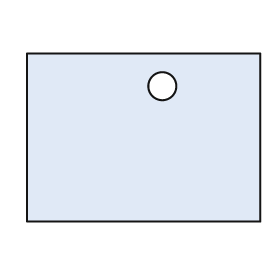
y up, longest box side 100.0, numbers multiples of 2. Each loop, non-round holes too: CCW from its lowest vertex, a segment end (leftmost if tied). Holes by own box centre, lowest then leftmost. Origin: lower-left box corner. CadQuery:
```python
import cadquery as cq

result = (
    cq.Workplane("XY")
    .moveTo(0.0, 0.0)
    .lineTo(100.0, 0.0)
    .lineTo(100.0, 72.0)
    .lineTo(0.0, 72.0)
    .close()
    .moveTo(58.0, 58.0)
    .circle(6.0)
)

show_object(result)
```